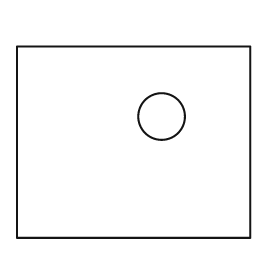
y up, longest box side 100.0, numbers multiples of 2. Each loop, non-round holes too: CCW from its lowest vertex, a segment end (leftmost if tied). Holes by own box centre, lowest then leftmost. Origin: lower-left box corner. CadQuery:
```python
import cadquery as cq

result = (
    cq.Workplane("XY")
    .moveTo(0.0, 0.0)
    .lineTo(100.0, 0.0)
    .lineTo(100.0, 82.0)
    .lineTo(0.0, 82.0)
    .close()
    .moveTo(62.0, 52.0)
    .circle(10.0)
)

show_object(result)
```